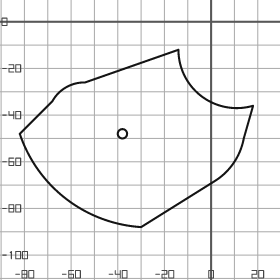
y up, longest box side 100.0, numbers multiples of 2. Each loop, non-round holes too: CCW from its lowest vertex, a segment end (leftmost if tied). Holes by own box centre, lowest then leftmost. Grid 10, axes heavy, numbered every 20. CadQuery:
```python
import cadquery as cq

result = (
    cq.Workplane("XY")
    .moveTo(-30.0, -88.0)
    .lineTo(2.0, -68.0)
    .threePointArc((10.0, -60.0), (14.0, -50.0))
    .lineTo(18.0, -36.0)
    .threePointArc((-4.0, -32.0), (-14.0, -12.0))
    .lineTo(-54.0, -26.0)
    .threePointArc((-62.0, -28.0), (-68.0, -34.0))
    .lineTo(-82.0, -48.0)
    .threePointArc((-62.0, -76.0), (-30.0, -88.0))
    .close()
    .moveTo(-38.0, -48.0)
    .circle(2.0)
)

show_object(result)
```